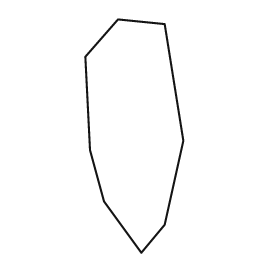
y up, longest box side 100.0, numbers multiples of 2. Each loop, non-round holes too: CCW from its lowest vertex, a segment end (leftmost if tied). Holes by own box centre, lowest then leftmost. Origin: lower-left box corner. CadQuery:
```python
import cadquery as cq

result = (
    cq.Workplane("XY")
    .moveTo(24.0, 0.0)
    .lineTo(34.0, 12.0)
    .lineTo(42.0, 48.0)
    .lineTo(34.0, 98.0)
    .lineTo(14.0, 100.0)
    .lineTo(0.0, 84.0)
    .lineTo(2.0, 44.0)
    .lineTo(8.0, 22.0)
    .close()
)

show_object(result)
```